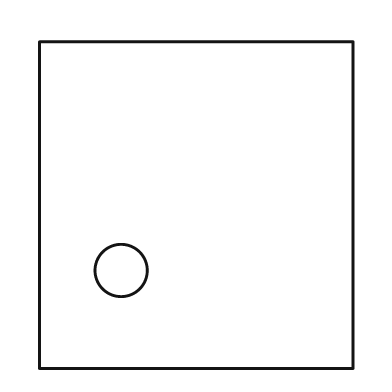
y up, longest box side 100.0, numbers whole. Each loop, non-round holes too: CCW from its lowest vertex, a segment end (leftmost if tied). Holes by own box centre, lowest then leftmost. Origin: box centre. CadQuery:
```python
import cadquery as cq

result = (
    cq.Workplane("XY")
    .moveTo(-48.0, -50.0)
    .lineTo(48.0, -50.0)
    .lineTo(48.0, 50.0)
    .lineTo(-48.0, 50.0)
    .close()
    .moveTo(-23.0, -20.0)
    .circle(8.0)
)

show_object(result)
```